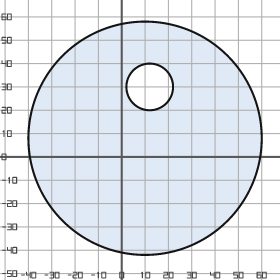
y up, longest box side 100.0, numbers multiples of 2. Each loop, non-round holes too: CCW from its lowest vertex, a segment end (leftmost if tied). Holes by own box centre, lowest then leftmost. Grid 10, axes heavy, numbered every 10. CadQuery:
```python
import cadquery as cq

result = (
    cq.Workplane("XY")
    .moveTo(10.0, 8.0)
    .circle(50.0)
    .moveTo(12.0, 30.0)
    .circle(10.0)
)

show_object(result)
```